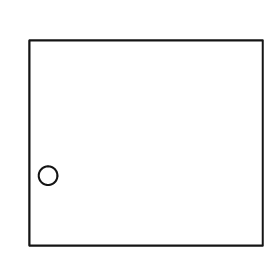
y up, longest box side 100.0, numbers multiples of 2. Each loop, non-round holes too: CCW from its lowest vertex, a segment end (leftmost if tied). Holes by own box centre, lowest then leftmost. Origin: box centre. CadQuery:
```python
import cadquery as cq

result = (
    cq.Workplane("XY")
    .moveTo(-50.0, -44.0)
    .lineTo(50.0, -44.0)
    .lineTo(50.0, 44.0)
    .lineTo(-50.0, 44.0)
    .close()
    .moveTo(-42.0, -14.0)
    .circle(4.0)
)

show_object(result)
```